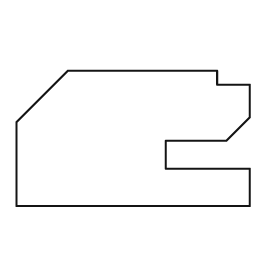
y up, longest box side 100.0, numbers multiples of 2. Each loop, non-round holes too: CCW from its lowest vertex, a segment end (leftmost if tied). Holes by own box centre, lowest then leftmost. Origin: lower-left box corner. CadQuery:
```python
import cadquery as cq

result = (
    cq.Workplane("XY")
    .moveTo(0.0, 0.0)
    .lineTo(100.0, 0.0)
    .lineTo(100.0, 16.0)
    .lineTo(64.0, 16.0)
    .lineTo(64.0, 28.0)
    .lineTo(90.0, 28.0)
    .lineTo(100.0, 38.0)
    .lineTo(100.0, 52.0)
    .lineTo(86.0, 52.0)
    .lineTo(86.0, 58.0)
    .lineTo(22.0, 58.0)
    .lineTo(0.0, 36.0)
    .close()
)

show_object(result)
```